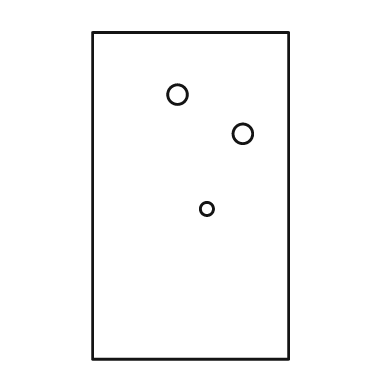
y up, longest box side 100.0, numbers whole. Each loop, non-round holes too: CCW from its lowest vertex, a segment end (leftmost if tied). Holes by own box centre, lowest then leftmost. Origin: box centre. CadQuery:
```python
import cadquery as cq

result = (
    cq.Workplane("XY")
    .moveTo(-30.0, -50.0)
    .lineTo(30.0, -50.0)
    .lineTo(30.0, 50.0)
    .lineTo(-30.0, 50.0)
    .close()
    .moveTo(5.0, -4.0)
    .circle(2.0)
    .moveTo(16.0, 19.0)
    .circle(3.0)
    .moveTo(-4.0, 31.0)
    .circle(3.0)
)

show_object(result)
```